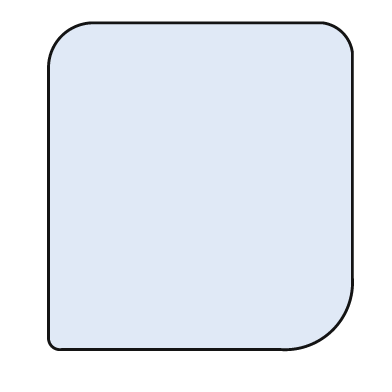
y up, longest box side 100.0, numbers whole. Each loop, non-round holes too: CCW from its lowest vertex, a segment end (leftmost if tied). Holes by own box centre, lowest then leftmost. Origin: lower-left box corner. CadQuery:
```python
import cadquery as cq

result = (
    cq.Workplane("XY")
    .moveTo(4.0, 0.0)
    .lineTo(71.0, 0.0)
    .threePointArc((87.0, 6.0), (93.0, 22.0))
    .lineTo(93.0, 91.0)
    .threePointArc((90.0, 97.0), (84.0, 100.0))
    .lineTo(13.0, 100.0)
    .threePointArc((4.0, 96.0), (0.0, 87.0))
    .lineTo(0.0, 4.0)
    .threePointArc((1.0, 1.0), (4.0, 0.0))
    .close()
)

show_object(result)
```